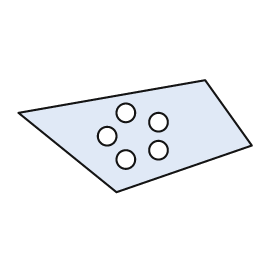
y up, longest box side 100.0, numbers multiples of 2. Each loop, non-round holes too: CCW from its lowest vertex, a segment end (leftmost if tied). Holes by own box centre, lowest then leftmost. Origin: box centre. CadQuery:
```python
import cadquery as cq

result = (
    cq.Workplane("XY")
    .moveTo(-8.0, -24.0)
    .lineTo(50.0, -4.0)
    .lineTo(30.0, 24.0)
    .lineTo(-50.0, 10.0)
    .close()
    .moveTo(-4.0, -10.0)
    .circle(4.0)
    .moveTo(10.0, -6.0)
    .circle(4.0)
    .moveTo(-12.0, 0.0)
    .circle(4.0)
    .moveTo(10.0, 6.0)
    .circle(4.0)
    .moveTo(-4.0, 10.0)
    .circle(4.0)
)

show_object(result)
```